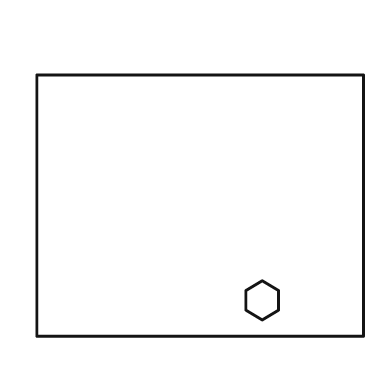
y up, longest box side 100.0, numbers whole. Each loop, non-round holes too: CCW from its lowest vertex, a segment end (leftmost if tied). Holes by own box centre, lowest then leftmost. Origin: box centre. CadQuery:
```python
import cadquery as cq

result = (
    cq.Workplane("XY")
    .moveTo(-50.0, -40.0)
    .lineTo(50.0, -40.0)
    .lineTo(50.0, 40.0)
    .lineTo(-50.0, 40.0)
    .close()
    .moveTo(19.0, -35.0)
    .lineTo(24.0, -32.0)
    .lineTo(24.0, -26.0)
    .lineTo(19.0, -23.0)
    .lineTo(14.0, -26.0)
    .lineTo(14.0, -32.0)
    .close()
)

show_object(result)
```